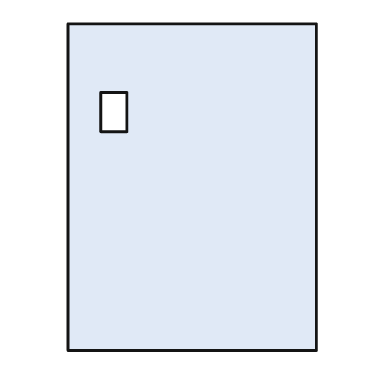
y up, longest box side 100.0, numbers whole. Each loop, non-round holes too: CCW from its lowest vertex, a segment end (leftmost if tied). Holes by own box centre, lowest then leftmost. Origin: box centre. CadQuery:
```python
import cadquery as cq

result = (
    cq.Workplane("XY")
    .moveTo(-38.0, -50.0)
    .lineTo(38.0, -50.0)
    .lineTo(38.0, 50.0)
    .lineTo(-38.0, 50.0)
    .close()
    .moveTo(-28.0, 17.0)
    .lineTo(-20.0, 17.0)
    .lineTo(-20.0, 29.0)
    .lineTo(-28.0, 29.0)
    .close()
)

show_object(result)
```